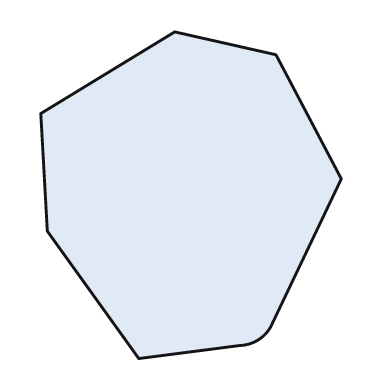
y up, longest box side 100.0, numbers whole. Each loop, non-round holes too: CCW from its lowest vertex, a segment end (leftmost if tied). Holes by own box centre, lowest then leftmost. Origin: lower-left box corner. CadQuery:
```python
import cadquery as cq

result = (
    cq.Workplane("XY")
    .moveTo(30.0, 0.0)
    .lineTo(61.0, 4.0)
    .threePointArc((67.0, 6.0), (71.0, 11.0))
    .lineTo(92.0, 55.0)
    .lineTo(72.0, 93.0)
    .lineTo(41.0, 100.0)
    .lineTo(0.0, 75.0)
    .lineTo(2.0, 39.0)
    .close()
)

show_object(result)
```